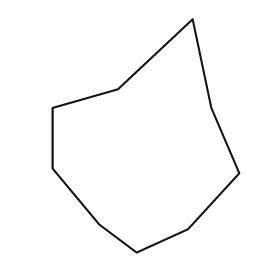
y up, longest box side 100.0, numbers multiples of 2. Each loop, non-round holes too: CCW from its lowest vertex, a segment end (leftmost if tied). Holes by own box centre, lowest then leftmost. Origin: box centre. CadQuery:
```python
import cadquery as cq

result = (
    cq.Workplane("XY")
    .moveTo(-4.0, -50.0)
    .lineTo(18.0, -40.0)
    .lineTo(40.0, -16.0)
    .lineTo(28.0, 12.0)
    .lineTo(20.0, 50.0)
    .lineTo(-12.0, 20.0)
    .lineTo(-40.0, 12.0)
    .lineTo(-40.0, -14.0)
    .lineTo(-20.0, -38.0)
    .close()
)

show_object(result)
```